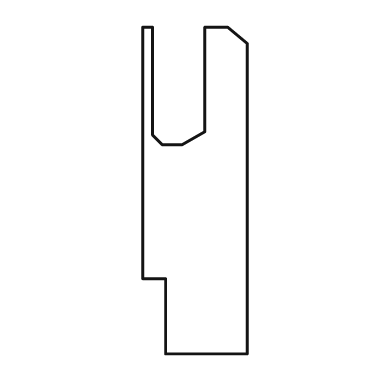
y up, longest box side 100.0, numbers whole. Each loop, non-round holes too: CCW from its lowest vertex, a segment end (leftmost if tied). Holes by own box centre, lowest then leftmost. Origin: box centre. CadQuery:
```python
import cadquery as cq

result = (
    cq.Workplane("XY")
    .moveTo(-9.0, -50.0)
    .lineTo(16.0, -50.0)
    .lineTo(16.0, 45.0)
    .lineTo(10.0, 50.0)
    .lineTo(3.0, 50.0)
    .lineTo(3.0, 18.0)
    .lineTo(-4.0, 14.0)
    .lineTo(-10.0, 14.0)
    .lineTo(-13.0, 17.0)
    .lineTo(-13.0, 50.0)
    .lineTo(-16.0, 50.0)
    .lineTo(-16.0, -27.0)
    .lineTo(-9.0, -27.0)
    .close()
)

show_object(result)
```